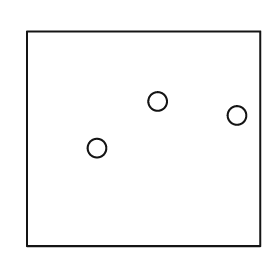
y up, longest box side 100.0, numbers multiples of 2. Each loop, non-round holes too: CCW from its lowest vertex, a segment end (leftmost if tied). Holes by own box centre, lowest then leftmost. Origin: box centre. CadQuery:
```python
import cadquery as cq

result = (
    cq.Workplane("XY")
    .moveTo(-50.0, -46.0)
    .lineTo(50.0, -46.0)
    .lineTo(50.0, 46.0)
    .lineTo(-50.0, 46.0)
    .close()
    .moveTo(-20.0, -4.0)
    .circle(4.0)
    .moveTo(40.0, 10.0)
    .circle(4.0)
    .moveTo(6.0, 16.0)
    .circle(4.0)
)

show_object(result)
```